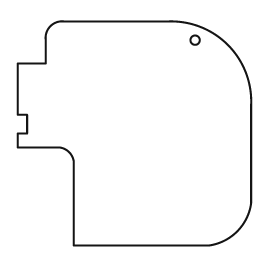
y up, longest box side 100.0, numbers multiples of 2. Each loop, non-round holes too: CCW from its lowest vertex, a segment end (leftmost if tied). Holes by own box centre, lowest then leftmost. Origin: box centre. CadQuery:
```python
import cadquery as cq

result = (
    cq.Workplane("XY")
    .moveTo(-26.0, -48.0)
    .lineTo(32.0, -48.0)
    .threePointArc((44.0, -42.0), (50.0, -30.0))
    .lineTo(50.0, 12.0)
    .threePointArc((40.0, 38.0), (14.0, 48.0))
    .lineTo(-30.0, 48.0)
    .threePointArc((-36.0, 46.0), (-38.0, 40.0))
    .lineTo(-38.0, 30.0)
    .lineTo(-50.0, 30.0)
    .lineTo(-50.0, 8.0)
    .lineTo(-46.0, 8.0)
    .lineTo(-46.0, 0.0)
    .lineTo(-50.0, 0.0)
    .lineTo(-50.0, -6.0)
    .lineTo(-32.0, -6.0)
    .threePointArc((-28.0, -8.0), (-26.0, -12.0))
    .close()
    .moveTo(26.0, 40.0)
    .circle(2.0)
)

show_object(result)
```